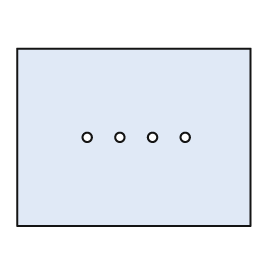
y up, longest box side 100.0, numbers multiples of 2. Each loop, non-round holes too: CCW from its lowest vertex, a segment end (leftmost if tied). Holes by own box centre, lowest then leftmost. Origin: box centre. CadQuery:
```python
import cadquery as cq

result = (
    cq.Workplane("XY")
    .moveTo(-50.0, -38.0)
    .lineTo(50.0, -38.0)
    .lineTo(50.0, 38.0)
    .lineTo(-50.0, 38.0)
    .close()
    .moveTo(-20.0, 0.0)
    .circle(2.0)
    .moveTo(-6.0, 0.0)
    .circle(2.0)
    .moveTo(8.0, 0.0)
    .circle(2.0)
    .moveTo(22.0, 0.0)
    .circle(2.0)
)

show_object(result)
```